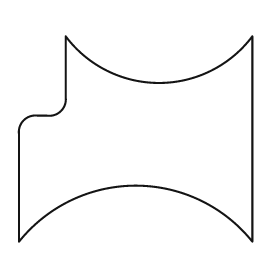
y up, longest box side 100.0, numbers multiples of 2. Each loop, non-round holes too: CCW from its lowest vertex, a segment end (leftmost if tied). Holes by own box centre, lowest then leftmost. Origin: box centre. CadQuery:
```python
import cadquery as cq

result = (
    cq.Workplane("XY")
    .moveTo(-50.0, -44.0)
    .threePointArc((0.0, -20.0), (50.0, -44.0))
    .lineTo(50.0, 44.0)
    .threePointArc((10.0, 24.0), (-30.0, 44.0))
    .lineTo(-30.0, 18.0)
    .threePointArc((-32.0, 12.0), (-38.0, 10.0))
    .lineTo(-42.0, 10.0)
    .threePointArc((-48.0, 8.0), (-50.0, 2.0))
    .close()
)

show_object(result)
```